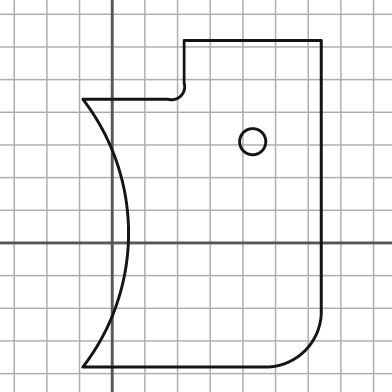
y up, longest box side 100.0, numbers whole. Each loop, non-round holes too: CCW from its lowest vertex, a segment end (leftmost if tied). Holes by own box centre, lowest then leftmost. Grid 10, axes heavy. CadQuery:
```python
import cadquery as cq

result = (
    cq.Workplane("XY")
    .moveTo(-9.0, -38.0)
    .lineTo(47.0, -38.0)
    .threePointArc((59.0, -33.0), (64.0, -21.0))
    .lineTo(64.0, 62.0)
    .lineTo(22.0, 62.0)
    .lineTo(22.0, 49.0)
    .threePointArc((21.0, 45.0), (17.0, 44.0))
    .lineTo(-9.0, 44.0)
    .threePointArc((5.0, 3.0), (-9.0, -38.0))
    .close()
    .moveTo(43.0, 31.0)
    .circle(4.0)
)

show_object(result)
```